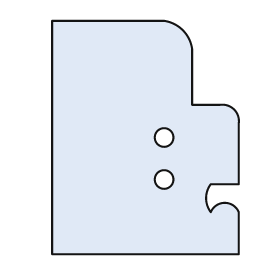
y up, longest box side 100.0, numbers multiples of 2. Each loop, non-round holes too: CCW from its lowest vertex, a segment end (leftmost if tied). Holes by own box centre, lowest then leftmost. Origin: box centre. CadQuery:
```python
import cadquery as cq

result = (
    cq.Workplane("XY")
    .moveTo(-40.0, -50.0)
    .lineTo(40.0, -50.0)
    .lineTo(40.0, -32.0)
    .threePointArc((34.0, -28.0), (28.0, -32.0))
    .threePointArc((26.0, -26.0), (28.0, -20.0))
    .lineTo(40.0, -20.0)
    .lineTo(40.0, 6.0)
    .threePointArc((38.0, 12.0), (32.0, 14.0))
    .lineTo(20.0, 14.0)
    .lineTo(20.0, 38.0)
    .threePointArc((16.0, 46.0), (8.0, 50.0))
    .lineTo(-40.0, 50.0)
    .close()
    .moveTo(8.0, -18.0)
    .circle(4.0)
    .moveTo(8.0, 0.0)
    .circle(4.0)
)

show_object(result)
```